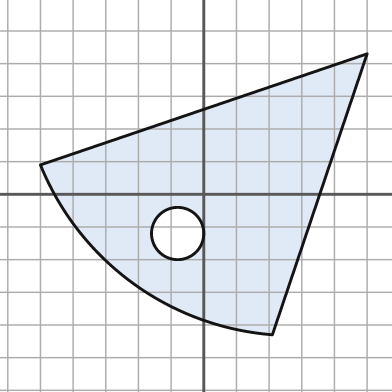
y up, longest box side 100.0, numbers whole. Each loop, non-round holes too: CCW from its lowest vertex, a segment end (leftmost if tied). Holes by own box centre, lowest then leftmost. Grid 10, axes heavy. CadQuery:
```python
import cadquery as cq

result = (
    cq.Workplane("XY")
    .moveTo(21.0, -43.0)
    .lineTo(50.0, 43.0)
    .lineTo(-50.0, 9.0)
    .threePointArc((-22.0, -27.0), (21.0, -43.0))
    .close()
    .moveTo(-8.0, -12.0)
    .circle(8.0)
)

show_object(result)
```